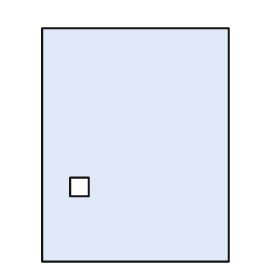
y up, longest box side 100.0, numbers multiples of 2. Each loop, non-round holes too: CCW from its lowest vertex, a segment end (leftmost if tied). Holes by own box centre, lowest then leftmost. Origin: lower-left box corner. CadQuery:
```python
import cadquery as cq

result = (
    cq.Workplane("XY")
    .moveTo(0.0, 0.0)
    .lineTo(80.0, 0.0)
    .lineTo(80.0, 100.0)
    .lineTo(0.0, 100.0)
    .close()
    .moveTo(12.0, 28.0)
    .lineTo(20.0, 28.0)
    .lineTo(20.0, 36.0)
    .lineTo(12.0, 36.0)
    .close()
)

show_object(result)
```